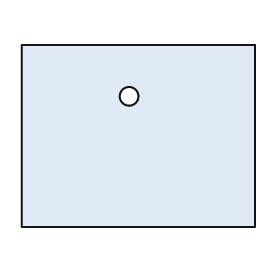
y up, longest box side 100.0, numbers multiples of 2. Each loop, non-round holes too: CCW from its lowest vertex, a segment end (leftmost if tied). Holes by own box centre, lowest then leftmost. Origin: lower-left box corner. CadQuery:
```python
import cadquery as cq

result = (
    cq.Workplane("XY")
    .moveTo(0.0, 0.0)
    .lineTo(100.0, 0.0)
    .lineTo(100.0, 78.0)
    .lineTo(0.0, 78.0)
    .close()
    .moveTo(46.0, 56.0)
    .circle(4.0)
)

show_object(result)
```